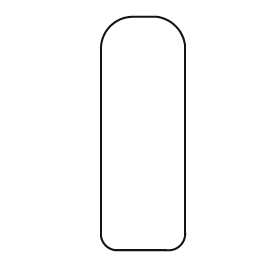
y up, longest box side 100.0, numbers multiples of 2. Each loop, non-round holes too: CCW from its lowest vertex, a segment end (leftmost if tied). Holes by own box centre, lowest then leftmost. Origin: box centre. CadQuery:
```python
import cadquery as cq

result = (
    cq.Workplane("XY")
    .moveTo(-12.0, -50.0)
    .lineTo(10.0, -50.0)
    .threePointArc((16.0, -48.0), (18.0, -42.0))
    .lineTo(18.0, 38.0)
    .threePointArc((14.0, 46.0), (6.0, 50.0))
    .lineTo(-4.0, 50.0)
    .threePointArc((-14.0, 46.0), (-18.0, 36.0))
    .lineTo(-18.0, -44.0)
    .threePointArc((-16.0, -48.0), (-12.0, -50.0))
    .close()
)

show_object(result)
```